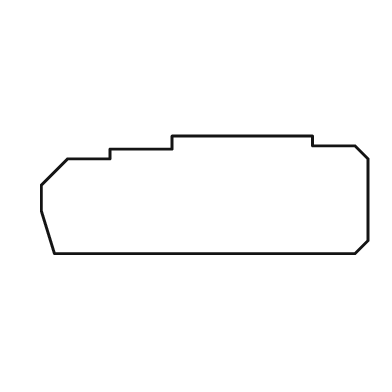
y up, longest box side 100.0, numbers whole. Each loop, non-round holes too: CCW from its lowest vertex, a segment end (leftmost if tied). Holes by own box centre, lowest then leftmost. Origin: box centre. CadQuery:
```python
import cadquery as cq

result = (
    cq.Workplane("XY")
    .moveTo(-46.0, -18.0)
    .lineTo(46.0, -18.0)
    .lineTo(50.0, -14.0)
    .lineTo(50.0, 11.0)
    .lineTo(46.0, 15.0)
    .lineTo(33.0, 15.0)
    .lineTo(33.0, 18.0)
    .lineTo(-10.0, 18.0)
    .lineTo(-10.0, 14.0)
    .lineTo(-29.0, 14.0)
    .lineTo(-29.0, 11.0)
    .lineTo(-42.0, 11.0)
    .lineTo(-50.0, 3.0)
    .lineTo(-50.0, -5.0)
    .close()
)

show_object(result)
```